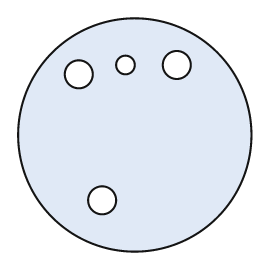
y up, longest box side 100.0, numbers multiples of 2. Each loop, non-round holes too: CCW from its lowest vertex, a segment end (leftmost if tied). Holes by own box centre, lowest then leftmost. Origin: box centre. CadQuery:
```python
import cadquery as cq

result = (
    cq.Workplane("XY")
    .moveTo(0.0, 0.0)
    .circle(50.0)
    .moveTo(-14.0, -28.0)
    .circle(6.0)
    .moveTo(-24.0, 26.0)
    .circle(6.0)
    .moveTo(-4.0, 30.0)
    .circle(4.0)
    .moveTo(18.0, 30.0)
    .circle(6.0)
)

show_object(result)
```